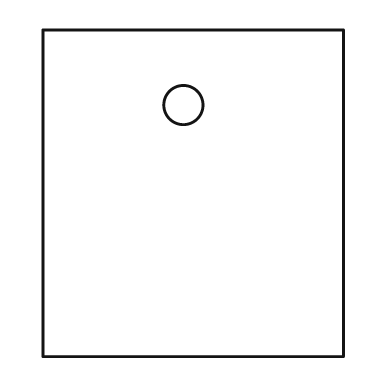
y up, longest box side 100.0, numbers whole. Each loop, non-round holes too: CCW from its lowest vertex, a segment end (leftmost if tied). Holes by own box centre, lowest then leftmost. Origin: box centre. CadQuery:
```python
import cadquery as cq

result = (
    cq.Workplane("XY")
    .moveTo(-46.0, -50.0)
    .lineTo(46.0, -50.0)
    .lineTo(46.0, 50.0)
    .lineTo(-46.0, 50.0)
    .close()
    .moveTo(-3.0, 27.0)
    .circle(6.0)
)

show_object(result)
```